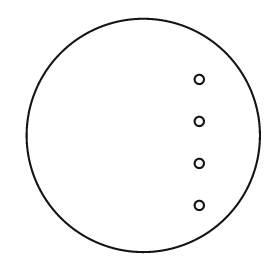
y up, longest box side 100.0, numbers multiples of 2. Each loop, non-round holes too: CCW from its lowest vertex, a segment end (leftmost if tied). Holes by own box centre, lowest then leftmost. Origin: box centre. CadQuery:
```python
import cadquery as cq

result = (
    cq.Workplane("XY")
    .moveTo(0.0, 0.0)
    .circle(50.0)
    .moveTo(24.0, -30.0)
    .circle(2.0)
    .moveTo(24.0, -12.0)
    .circle(2.0)
    .moveTo(24.0, 6.0)
    .circle(2.0)
    .moveTo(24.0, 24.0)
    .circle(2.0)
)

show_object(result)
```